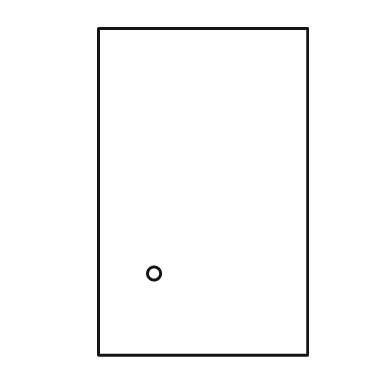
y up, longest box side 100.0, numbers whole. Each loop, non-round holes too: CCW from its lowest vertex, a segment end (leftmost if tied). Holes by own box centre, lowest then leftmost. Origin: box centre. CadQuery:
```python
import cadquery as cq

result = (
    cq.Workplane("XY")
    .moveTo(-32.0, -50.0)
    .lineTo(32.0, -50.0)
    .lineTo(32.0, 50.0)
    .lineTo(-32.0, 50.0)
    .close()
    .moveTo(-15.0, -25.0)
    .circle(2.0)
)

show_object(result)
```